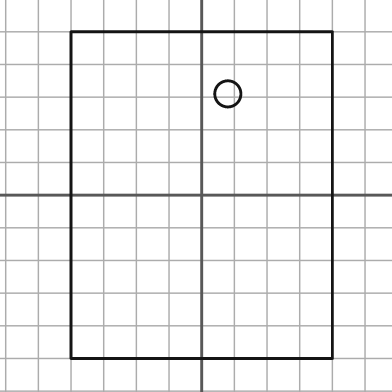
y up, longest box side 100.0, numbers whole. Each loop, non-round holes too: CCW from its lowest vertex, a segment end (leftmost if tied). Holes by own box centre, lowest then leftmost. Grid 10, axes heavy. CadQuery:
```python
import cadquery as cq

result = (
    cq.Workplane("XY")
    .moveTo(-40.0, -50.0)
    .lineTo(40.0, -50.0)
    .lineTo(40.0, 50.0)
    .lineTo(-40.0, 50.0)
    .close()
    .moveTo(8.0, 31.0)
    .circle(4.0)
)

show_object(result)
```